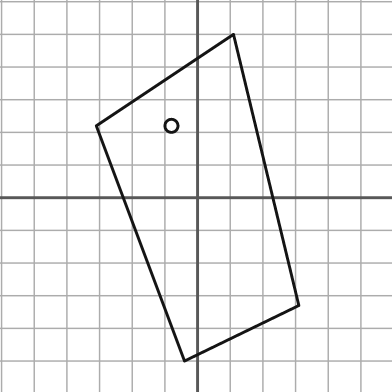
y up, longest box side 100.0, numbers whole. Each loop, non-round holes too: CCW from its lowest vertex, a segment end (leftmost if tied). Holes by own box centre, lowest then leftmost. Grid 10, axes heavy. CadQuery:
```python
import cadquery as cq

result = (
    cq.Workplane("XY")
    .moveTo(-4.0, -50.0)
    .lineTo(31.0, -33.0)
    .lineTo(11.0, 50.0)
    .lineTo(-31.0, 22.0)
    .close()
    .moveTo(-8.0, 22.0)
    .circle(2.0)
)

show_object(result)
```